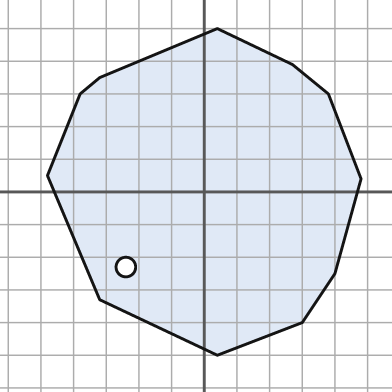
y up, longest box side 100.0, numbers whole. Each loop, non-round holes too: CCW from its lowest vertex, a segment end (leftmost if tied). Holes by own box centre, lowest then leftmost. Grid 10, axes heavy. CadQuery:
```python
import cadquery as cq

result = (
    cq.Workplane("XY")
    .moveTo(4.0, -50.0)
    .lineTo(30.0, -40.0)
    .lineTo(40.0, -25.0)
    .lineTo(48.0, 4.0)
    .lineTo(38.0, 30.0)
    .lineTo(27.0, 39.0)
    .lineTo(4.0, 50.0)
    .lineTo(-32.0, 35.0)
    .lineTo(-38.0, 30.0)
    .lineTo(-48.0, 5.0)
    .lineTo(-32.0, -33.0)
    .close()
    .moveTo(-24.0, -23.0)
    .circle(3.0)
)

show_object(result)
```